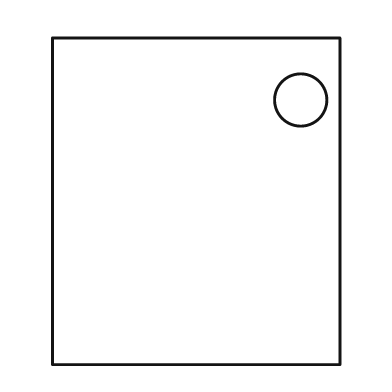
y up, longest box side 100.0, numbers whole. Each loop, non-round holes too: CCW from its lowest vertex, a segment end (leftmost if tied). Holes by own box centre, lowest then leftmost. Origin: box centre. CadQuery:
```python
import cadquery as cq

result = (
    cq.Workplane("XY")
    .moveTo(-44.0, -50.0)
    .lineTo(44.0, -50.0)
    .lineTo(44.0, 50.0)
    .lineTo(-44.0, 50.0)
    .close()
    .moveTo(32.0, 31.0)
    .circle(8.0)
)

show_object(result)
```